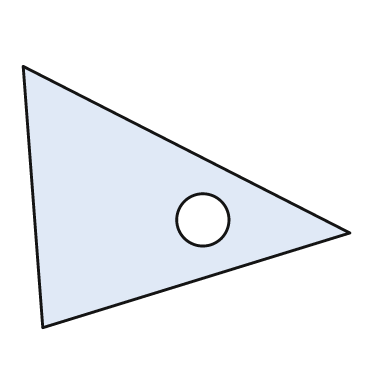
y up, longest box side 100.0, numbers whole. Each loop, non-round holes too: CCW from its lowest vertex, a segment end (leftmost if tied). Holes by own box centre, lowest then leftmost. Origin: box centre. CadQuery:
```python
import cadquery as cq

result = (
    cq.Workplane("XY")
    .moveTo(-44.0, -40.0)
    .lineTo(50.0, -11.0)
    .lineTo(-50.0, 40.0)
    .close()
    .moveTo(5.0, -7.0)
    .circle(8.0)
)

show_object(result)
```